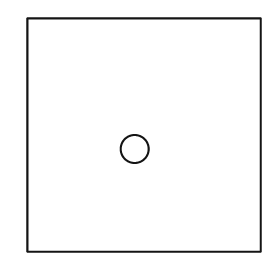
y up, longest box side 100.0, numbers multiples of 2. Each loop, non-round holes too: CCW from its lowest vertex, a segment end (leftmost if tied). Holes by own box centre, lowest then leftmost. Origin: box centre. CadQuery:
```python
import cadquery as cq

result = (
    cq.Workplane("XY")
    .moveTo(-50.0, -50.0)
    .lineTo(50.0, -50.0)
    .lineTo(50.0, 50.0)
    .lineTo(-50.0, 50.0)
    .close()
    .moveTo(-4.0, -6.0)
    .circle(6.0)
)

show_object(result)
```